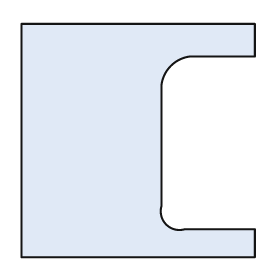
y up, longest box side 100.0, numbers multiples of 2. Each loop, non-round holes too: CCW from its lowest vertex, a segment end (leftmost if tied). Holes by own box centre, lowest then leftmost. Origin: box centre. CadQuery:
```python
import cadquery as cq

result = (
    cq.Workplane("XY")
    .moveTo(-50.0, -50.0)
    .lineTo(50.0, -50.0)
    .lineTo(50.0, -38.0)
    .lineTo(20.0, -38.0)
    .threePointArc((12.0, -36.0), (10.0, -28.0))
    .lineTo(10.0, 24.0)
    .threePointArc((14.0, 32.0), (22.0, 36.0))
    .lineTo(50.0, 36.0)
    .lineTo(50.0, 50.0)
    .lineTo(-50.0, 50.0)
    .close()
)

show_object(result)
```